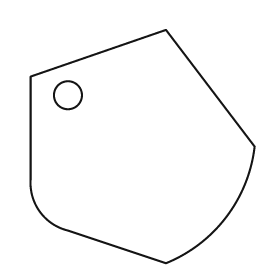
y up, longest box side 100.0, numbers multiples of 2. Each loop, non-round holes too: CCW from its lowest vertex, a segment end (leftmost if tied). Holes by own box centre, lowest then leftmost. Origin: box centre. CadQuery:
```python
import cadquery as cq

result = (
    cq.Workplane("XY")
    .moveTo(10.0, -50.0)
    .threePointArc((36.0, -30.0), (48.0, 0.0))
    .lineTo(10.0, 50.0)
    .lineTo(-48.0, 30.0)
    .lineTo(-48.0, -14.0)
    .threePointArc((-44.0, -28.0), (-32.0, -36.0))
    .close()
    .moveTo(-32.0, 22.0)
    .circle(6.0)
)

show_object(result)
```